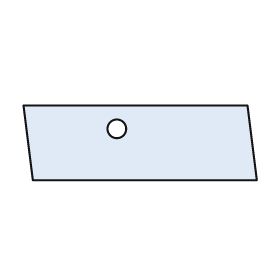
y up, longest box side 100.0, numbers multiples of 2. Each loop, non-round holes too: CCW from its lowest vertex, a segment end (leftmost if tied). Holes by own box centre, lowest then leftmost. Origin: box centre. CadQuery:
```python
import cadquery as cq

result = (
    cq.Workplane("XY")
    .moveTo(-46.0, -16.0)
    .lineTo(50.0, -16.0)
    .lineTo(46.0, 16.0)
    .lineTo(-50.0, 16.0)
    .close()
    .moveTo(-10.0, 6.0)
    .circle(4.0)
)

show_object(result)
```